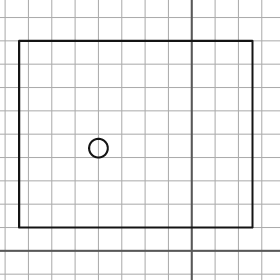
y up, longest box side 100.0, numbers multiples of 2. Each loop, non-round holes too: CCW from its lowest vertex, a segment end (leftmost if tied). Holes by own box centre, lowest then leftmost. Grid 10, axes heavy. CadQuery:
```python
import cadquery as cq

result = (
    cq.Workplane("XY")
    .moveTo(-74.0, 10.0)
    .lineTo(26.0, 10.0)
    .lineTo(26.0, 90.0)
    .lineTo(-74.0, 90.0)
    .close()
    .moveTo(-40.0, 44.0)
    .circle(4.0)
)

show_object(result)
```